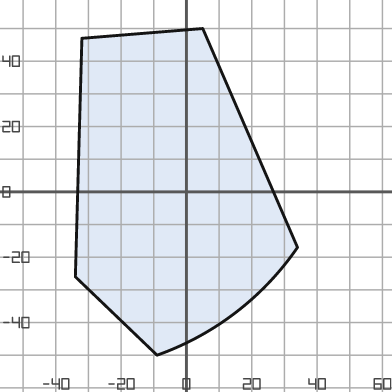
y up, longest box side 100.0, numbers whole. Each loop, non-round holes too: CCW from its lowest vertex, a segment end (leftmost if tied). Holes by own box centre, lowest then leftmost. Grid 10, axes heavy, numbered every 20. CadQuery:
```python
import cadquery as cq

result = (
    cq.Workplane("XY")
    .moveTo(-9.0, -50.0)
    .threePointArc((15.0, -37.0), (34.0, -17.0))
    .lineTo(5.0, 50.0)
    .lineTo(-32.0, 47.0)
    .lineTo(-34.0, -26.0)
    .close()
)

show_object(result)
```